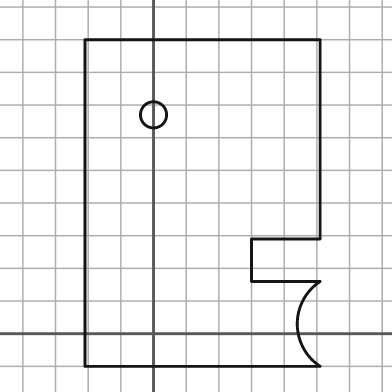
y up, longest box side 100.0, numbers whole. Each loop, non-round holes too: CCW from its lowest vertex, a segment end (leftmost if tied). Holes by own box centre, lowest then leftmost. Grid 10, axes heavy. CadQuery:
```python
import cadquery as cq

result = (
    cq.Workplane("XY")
    .moveTo(-21.0, -10.0)
    .lineTo(51.0, -10.0)
    .threePointArc((44.0, 3.0), (51.0, 16.0))
    .lineTo(30.0, 16.0)
    .lineTo(30.0, 29.0)
    .lineTo(51.0, 29.0)
    .lineTo(51.0, 90.0)
    .lineTo(-21.0, 90.0)
    .close()
    .moveTo(0.0, 67.0)
    .circle(4.0)
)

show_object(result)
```